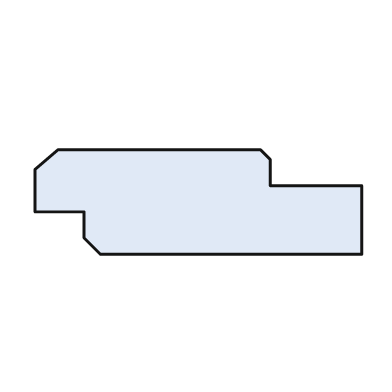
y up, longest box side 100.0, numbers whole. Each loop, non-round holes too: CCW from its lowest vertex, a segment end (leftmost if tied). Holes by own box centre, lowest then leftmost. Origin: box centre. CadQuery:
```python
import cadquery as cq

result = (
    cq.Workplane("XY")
    .moveTo(-30.0, -16.0)
    .lineTo(50.0, -16.0)
    .lineTo(50.0, 5.0)
    .lineTo(22.0, 5.0)
    .lineTo(22.0, 13.0)
    .lineTo(19.0, 16.0)
    .lineTo(-43.0, 16.0)
    .lineTo(-50.0, 10.0)
    .lineTo(-50.0, -3.0)
    .lineTo(-35.0, -3.0)
    .lineTo(-35.0, -11.0)
    .close()
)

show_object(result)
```